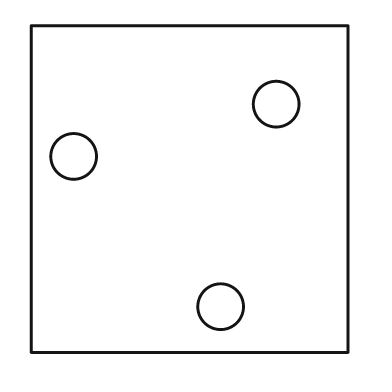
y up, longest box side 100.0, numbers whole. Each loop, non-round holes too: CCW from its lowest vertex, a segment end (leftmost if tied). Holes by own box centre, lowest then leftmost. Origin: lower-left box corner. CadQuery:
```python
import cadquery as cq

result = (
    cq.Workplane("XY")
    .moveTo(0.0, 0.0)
    .lineTo(97.0, 0.0)
    .lineTo(97.0, 100.0)
    .lineTo(0.0, 100.0)
    .close()
    .moveTo(58.0, 14.0)
    .circle(7.0)
    .moveTo(13.0, 60.0)
    .circle(7.0)
    .moveTo(75.0, 76.0)
    .circle(7.0)
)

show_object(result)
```